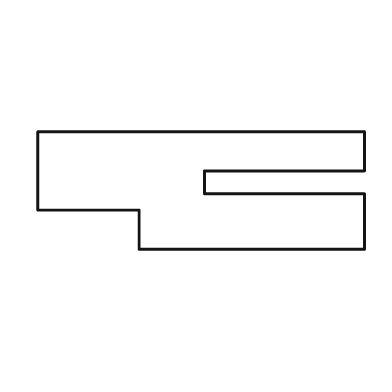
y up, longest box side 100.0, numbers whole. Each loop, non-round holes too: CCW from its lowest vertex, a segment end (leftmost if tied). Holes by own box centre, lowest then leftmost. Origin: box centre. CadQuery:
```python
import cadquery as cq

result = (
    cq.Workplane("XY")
    .moveTo(-19.0, -18.0)
    .lineTo(50.0, -18.0)
    .lineTo(50.0, -1.0)
    .lineTo(1.0, -1.0)
    .lineTo(1.0, 6.0)
    .lineTo(50.0, 6.0)
    .lineTo(50.0, 18.0)
    .lineTo(-50.0, 18.0)
    .lineTo(-50.0, -6.0)
    .lineTo(-19.0, -6.0)
    .close()
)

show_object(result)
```